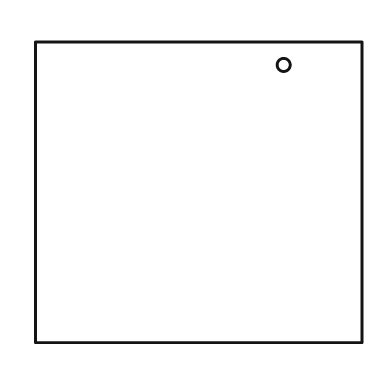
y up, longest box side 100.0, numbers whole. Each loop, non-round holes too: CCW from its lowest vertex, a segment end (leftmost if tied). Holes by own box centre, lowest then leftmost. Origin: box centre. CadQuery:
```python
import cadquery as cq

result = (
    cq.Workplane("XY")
    .moveTo(-50.0, -46.0)
    .lineTo(50.0, -46.0)
    .lineTo(50.0, 46.0)
    .lineTo(-50.0, 46.0)
    .close()
    .moveTo(26.0, 39.0)
    .circle(2.0)
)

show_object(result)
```